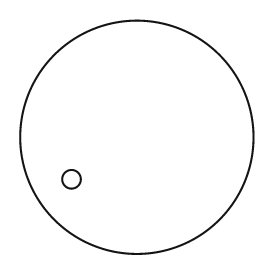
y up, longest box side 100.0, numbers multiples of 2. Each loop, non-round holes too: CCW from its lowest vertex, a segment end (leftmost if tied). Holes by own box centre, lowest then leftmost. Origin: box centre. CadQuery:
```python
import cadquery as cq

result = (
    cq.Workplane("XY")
    .moveTo(0.0, 0.0)
    .circle(50.0)
    .moveTo(-28.0, -18.0)
    .circle(4.0)
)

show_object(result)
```